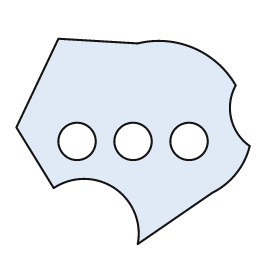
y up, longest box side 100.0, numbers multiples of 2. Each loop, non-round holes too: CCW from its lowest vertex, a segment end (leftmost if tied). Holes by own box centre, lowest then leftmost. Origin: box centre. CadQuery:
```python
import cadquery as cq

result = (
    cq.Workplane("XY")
    .moveTo(2.0, -44.0)
    .lineTo(34.0, -22.0)
    .threePointArc((44.0, -14.0), (50.0, -2.0))
    .threePointArc((42.0, 10.0), (44.0, 24.0))
    .threePointArc((26.0, 40.0), (2.0, 42.0))
    .lineTo(-32.0, 44.0)
    .lineTo(-50.0, 6.0)
    .lineTo(-34.0, -20.0)
    .threePointArc((-8.0, -20.0), (2.0, -44.0))
    .close()
    .moveTo(-24.0, 0.0)
    .circle(8.0)
    .moveTo(0.0, 0.0)
    .circle(8.0)
    .moveTo(24.0, 0.0)
    .circle(8.0)
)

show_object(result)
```